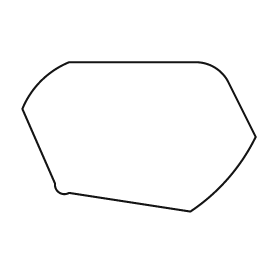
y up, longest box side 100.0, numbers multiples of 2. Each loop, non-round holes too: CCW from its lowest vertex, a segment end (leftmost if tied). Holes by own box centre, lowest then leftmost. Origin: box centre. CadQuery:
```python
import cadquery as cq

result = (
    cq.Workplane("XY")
    .moveTo(22.0, -32.0)
    .threePointArc((38.0, -18.0), (50.0, 0.0))
    .lineTo(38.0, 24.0)
    .threePointArc((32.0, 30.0), (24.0, 32.0))
    .lineTo(-30.0, 32.0)
    .threePointArc((-42.0, 24.0), (-50.0, 12.0))
    .lineTo(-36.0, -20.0)
    .threePointArc((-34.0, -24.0), (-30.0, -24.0))
    .close()
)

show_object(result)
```